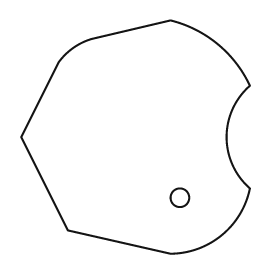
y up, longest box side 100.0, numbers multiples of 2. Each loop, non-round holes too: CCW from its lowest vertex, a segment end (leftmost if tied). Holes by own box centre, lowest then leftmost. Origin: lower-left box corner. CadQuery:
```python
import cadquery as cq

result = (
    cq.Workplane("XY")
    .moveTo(64.0, 0.0)
    .threePointArc((86.0, 8.0), (98.0, 28.0))
    .threePointArc((88.0, 50.0), (98.0, 72.0))
    .threePointArc((84.0, 90.0), (64.0, 100.0))
    .lineTo(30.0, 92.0)
    .threePointArc((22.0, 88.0), (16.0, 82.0))
    .lineTo(0.0, 50.0)
    .lineTo(20.0, 10.0)
    .close()
    .moveTo(68.0, 24.0)
    .circle(4.0)
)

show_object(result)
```